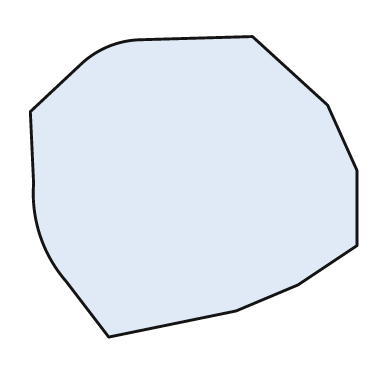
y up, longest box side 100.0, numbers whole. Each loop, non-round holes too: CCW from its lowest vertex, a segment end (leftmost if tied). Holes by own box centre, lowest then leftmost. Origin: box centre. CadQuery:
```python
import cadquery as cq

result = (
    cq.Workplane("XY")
    .moveTo(-26.0, -46.0)
    .lineTo(13.0, -38.0)
    .lineTo(32.0, -30.0)
    .lineTo(50.0, -18.0)
    .lineTo(50.0, 5.0)
    .lineTo(41.0, 25.0)
    .lineTo(18.0, 46.0)
    .lineTo(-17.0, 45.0)
    .threePointArc((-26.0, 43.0), (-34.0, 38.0))
    .lineTo(-50.0, 23.0)
    .lineTo(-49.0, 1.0)
    .threePointArc((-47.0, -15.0), (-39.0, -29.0))
    .close()
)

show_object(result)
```